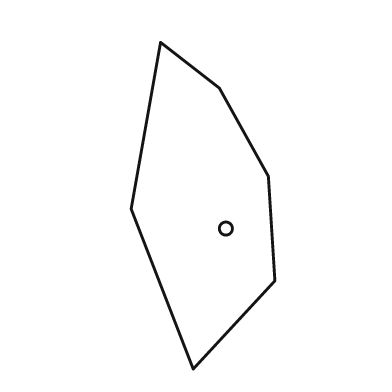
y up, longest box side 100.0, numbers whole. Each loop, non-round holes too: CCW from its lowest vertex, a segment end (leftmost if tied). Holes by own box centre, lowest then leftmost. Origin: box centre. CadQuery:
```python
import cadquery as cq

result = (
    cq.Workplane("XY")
    .moveTo(-3.0, -50.0)
    .lineTo(22.0, -23.0)
    .lineTo(20.0, 9.0)
    .lineTo(5.0, 36.0)
    .lineTo(-13.0, 50.0)
    .lineTo(-22.0, -1.0)
    .close()
    .moveTo(7.0, -7.0)
    .circle(2.0)
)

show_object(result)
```